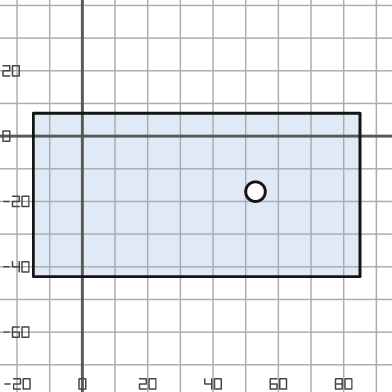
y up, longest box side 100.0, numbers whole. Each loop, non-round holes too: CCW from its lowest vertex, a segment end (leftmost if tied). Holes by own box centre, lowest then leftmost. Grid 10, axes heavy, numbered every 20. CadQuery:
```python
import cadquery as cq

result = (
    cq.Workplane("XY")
    .moveTo(-15.0, -43.0)
    .lineTo(85.0, -43.0)
    .lineTo(85.0, 7.0)
    .lineTo(-15.0, 7.0)
    .close()
    .moveTo(53.0, -17.0)
    .circle(3.0)
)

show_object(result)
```